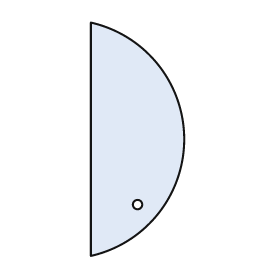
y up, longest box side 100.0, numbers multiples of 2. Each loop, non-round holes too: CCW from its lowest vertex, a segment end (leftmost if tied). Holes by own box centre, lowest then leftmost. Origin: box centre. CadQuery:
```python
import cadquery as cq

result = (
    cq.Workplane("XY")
    .moveTo(-20.0, -50.0)
    .threePointArc((20.0, 0.0), (-20.0, 50.0))
    .close()
    .moveTo(0.0, -28.0)
    .circle(2.0)
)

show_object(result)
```